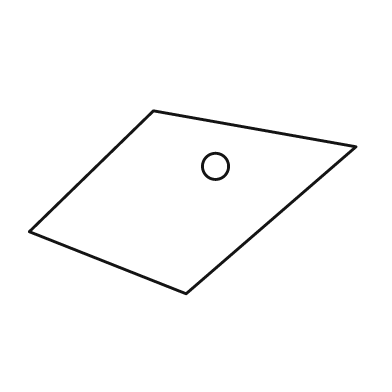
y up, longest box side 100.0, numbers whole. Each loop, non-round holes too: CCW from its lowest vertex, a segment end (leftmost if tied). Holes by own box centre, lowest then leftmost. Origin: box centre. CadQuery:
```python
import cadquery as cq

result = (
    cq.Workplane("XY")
    .moveTo(-2.0, -28.0)
    .lineTo(50.0, 17.0)
    .lineTo(-12.0, 28.0)
    .lineTo(-50.0, -9.0)
    .close()
    .moveTo(7.0, 11.0)
    .circle(4.0)
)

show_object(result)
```